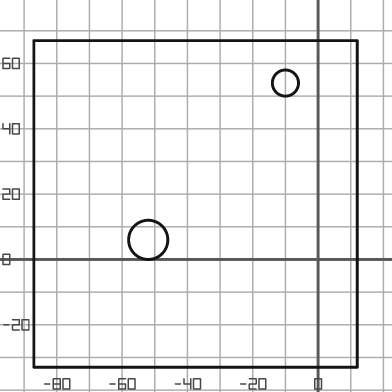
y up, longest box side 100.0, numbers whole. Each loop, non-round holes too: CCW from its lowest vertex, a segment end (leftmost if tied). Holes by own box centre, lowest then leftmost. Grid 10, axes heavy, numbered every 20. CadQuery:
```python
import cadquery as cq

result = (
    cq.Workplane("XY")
    .moveTo(-87.0, -33.0)
    .lineTo(12.0, -33.0)
    .lineTo(12.0, 67.0)
    .lineTo(-87.0, 67.0)
    .close()
    .moveTo(-52.0, 6.0)
    .circle(6.0)
    .moveTo(-10.0, 54.0)
    .circle(4.0)
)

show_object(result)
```